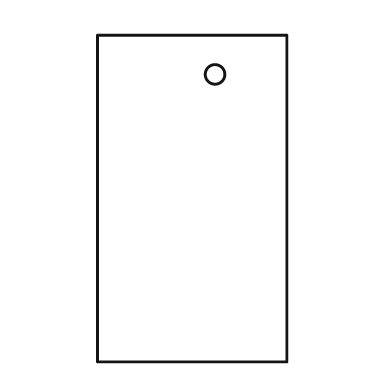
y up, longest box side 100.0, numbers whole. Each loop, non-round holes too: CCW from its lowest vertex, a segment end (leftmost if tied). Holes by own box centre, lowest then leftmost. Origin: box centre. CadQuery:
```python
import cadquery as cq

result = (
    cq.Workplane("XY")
    .moveTo(-29.0, -50.0)
    .lineTo(29.0, -50.0)
    .lineTo(29.0, 50.0)
    .lineTo(-29.0, 50.0)
    .close()
    .moveTo(7.0, 38.0)
    .circle(3.0)
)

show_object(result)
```